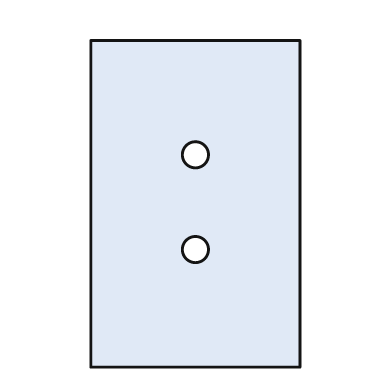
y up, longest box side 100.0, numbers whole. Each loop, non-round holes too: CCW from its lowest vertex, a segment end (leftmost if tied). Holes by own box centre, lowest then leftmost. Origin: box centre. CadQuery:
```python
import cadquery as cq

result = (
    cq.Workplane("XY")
    .moveTo(-32.0, -50.0)
    .lineTo(32.0, -50.0)
    .lineTo(32.0, 50.0)
    .lineTo(-32.0, 50.0)
    .close()
    .moveTo(0.0, -14.0)
    .circle(4.0)
    .moveTo(0.0, 15.0)
    .circle(4.0)
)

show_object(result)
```